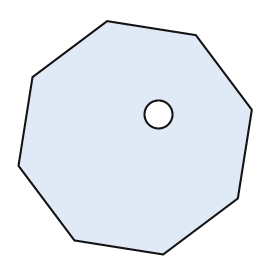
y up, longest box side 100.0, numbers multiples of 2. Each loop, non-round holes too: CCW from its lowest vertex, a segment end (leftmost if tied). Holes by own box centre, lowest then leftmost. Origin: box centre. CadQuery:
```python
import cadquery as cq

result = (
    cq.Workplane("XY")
    .moveTo(12.0, -50.0)
    .lineTo(44.0, -26.0)
    .lineTo(50.0, 12.0)
    .lineTo(26.0, 44.0)
    .lineTo(-12.0, 50.0)
    .lineTo(-44.0, 26.0)
    .lineTo(-50.0, -12.0)
    .lineTo(-26.0, -44.0)
    .close()
    .moveTo(10.0, 10.0)
    .circle(6.0)
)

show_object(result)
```